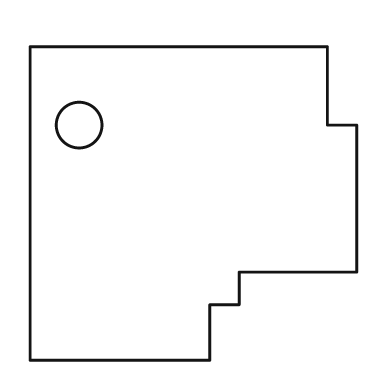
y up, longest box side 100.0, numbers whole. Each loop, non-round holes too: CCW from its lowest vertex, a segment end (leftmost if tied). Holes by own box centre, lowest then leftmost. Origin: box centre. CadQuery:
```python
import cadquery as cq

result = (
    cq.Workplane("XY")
    .moveTo(-50.0, -48.0)
    .lineTo(5.0, -48.0)
    .lineTo(5.0, -31.0)
    .lineTo(14.0, -31.0)
    .lineTo(14.0, -21.0)
    .lineTo(50.0, -21.0)
    .lineTo(50.0, 24.0)
    .lineTo(41.0, 24.0)
    .lineTo(41.0, 48.0)
    .lineTo(-50.0, 48.0)
    .close()
    .moveTo(-35.0, 24.0)
    .circle(7.0)
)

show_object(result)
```